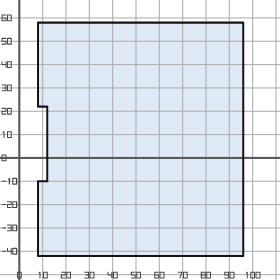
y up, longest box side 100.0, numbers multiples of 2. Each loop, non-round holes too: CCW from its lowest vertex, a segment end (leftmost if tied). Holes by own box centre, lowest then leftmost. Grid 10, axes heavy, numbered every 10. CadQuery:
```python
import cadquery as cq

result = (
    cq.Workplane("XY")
    .moveTo(8.0, -42.0)
    .lineTo(96.0, -42.0)
    .lineTo(96.0, 58.0)
    .lineTo(8.0, 58.0)
    .lineTo(8.0, 22.0)
    .lineTo(12.0, 22.0)
    .lineTo(12.0, -10.0)
    .lineTo(8.0, -10.0)
    .close()
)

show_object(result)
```